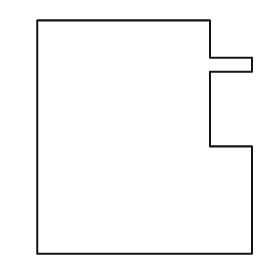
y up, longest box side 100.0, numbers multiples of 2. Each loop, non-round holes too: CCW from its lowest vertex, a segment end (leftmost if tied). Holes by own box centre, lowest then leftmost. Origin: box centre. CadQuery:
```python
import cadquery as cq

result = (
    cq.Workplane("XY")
    .moveTo(-46.0, -50.0)
    .lineTo(46.0, -50.0)
    .lineTo(46.0, -4.0)
    .lineTo(28.0, -4.0)
    .lineTo(28.0, 28.0)
    .lineTo(46.0, 28.0)
    .lineTo(46.0, 34.0)
    .lineTo(28.0, 34.0)
    .lineTo(28.0, 50.0)
    .lineTo(-46.0, 50.0)
    .close()
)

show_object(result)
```